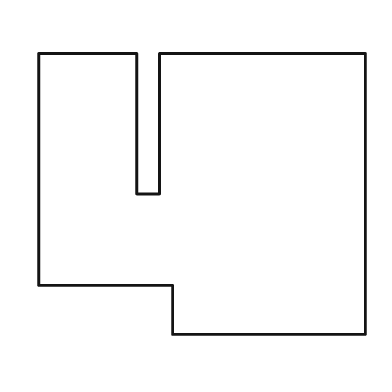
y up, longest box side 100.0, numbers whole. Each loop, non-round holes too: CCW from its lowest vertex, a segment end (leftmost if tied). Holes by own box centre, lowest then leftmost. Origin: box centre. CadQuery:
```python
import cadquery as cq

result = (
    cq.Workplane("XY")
    .moveTo(-9.0, -43.0)
    .lineTo(50.0, -43.0)
    .lineTo(50.0, 43.0)
    .lineTo(-13.0, 43.0)
    .lineTo(-13.0, 0.0)
    .lineTo(-20.0, 0.0)
    .lineTo(-20.0, 43.0)
    .lineTo(-50.0, 43.0)
    .lineTo(-50.0, -28.0)
    .lineTo(-9.0, -28.0)
    .close()
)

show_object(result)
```